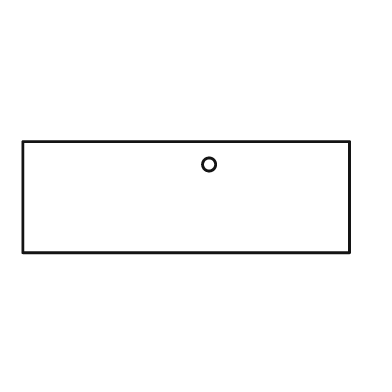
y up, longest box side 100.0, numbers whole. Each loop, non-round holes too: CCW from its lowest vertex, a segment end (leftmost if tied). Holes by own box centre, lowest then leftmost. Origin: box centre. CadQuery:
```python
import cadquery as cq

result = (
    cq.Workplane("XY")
    .moveTo(-50.0, -17.0)
    .lineTo(50.0, -17.0)
    .lineTo(50.0, 17.0)
    .lineTo(-50.0, 17.0)
    .close()
    .moveTo(7.0, 10.0)
    .circle(2.0)
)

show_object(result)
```